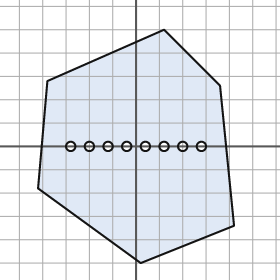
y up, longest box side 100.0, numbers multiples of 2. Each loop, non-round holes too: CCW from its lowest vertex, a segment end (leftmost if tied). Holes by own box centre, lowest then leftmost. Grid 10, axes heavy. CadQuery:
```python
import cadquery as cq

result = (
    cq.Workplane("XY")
    .moveTo(2.0, -50.0)
    .lineTo(42.0, -34.0)
    .lineTo(36.0, 26.0)
    .lineTo(12.0, 50.0)
    .lineTo(-38.0, 28.0)
    .lineTo(-42.0, -18.0)
    .close()
    .moveTo(-28.0, 0.0)
    .circle(2.0)
    .moveTo(-20.0, 0.0)
    .circle(2.0)
    .moveTo(-12.0, 0.0)
    .circle(2.0)
    .moveTo(-4.0, 0.0)
    .circle(2.0)
    .moveTo(4.0, 0.0)
    .circle(2.0)
    .moveTo(12.0, 0.0)
    .circle(2.0)
    .moveTo(20.0, 0.0)
    .circle(2.0)
    .moveTo(28.0, 0.0)
    .circle(2.0)
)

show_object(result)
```